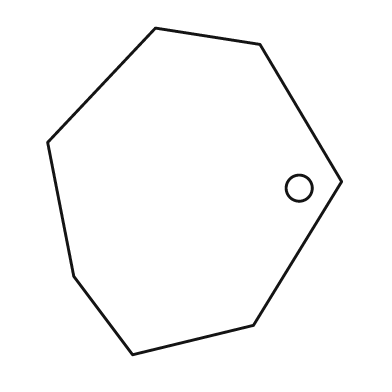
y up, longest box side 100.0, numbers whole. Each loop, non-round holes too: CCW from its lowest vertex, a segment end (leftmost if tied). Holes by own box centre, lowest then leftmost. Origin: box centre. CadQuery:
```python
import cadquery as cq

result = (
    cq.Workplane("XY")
    .moveTo(-19.0, -50.0)
    .lineTo(18.0, -41.0)
    .lineTo(45.0, 3.0)
    .lineTo(20.0, 45.0)
    .lineTo(-12.0, 50.0)
    .lineTo(-45.0, 15.0)
    .lineTo(-37.0, -26.0)
    .close()
    .moveTo(32.0, 1.0)
    .circle(4.0)
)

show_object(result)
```